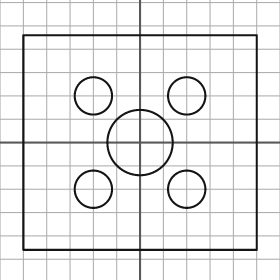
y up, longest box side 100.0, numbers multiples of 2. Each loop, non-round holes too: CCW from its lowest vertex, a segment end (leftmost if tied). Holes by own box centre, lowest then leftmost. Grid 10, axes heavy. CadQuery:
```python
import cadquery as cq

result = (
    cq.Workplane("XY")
    .moveTo(-50.0, -46.0)
    .lineTo(50.0, -46.0)
    .lineTo(50.0, 46.0)
    .lineTo(-50.0, 46.0)
    .close()
    .moveTo(-20.0, -20.0)
    .circle(8.0)
    .moveTo(20.0, -20.0)
    .circle(8.0)
    .moveTo(0.0, 0.0)
    .circle(14.0)
    .moveTo(-20.0, 20.0)
    .circle(8.0)
    .moveTo(20.0, 20.0)
    .circle(8.0)
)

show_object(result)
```